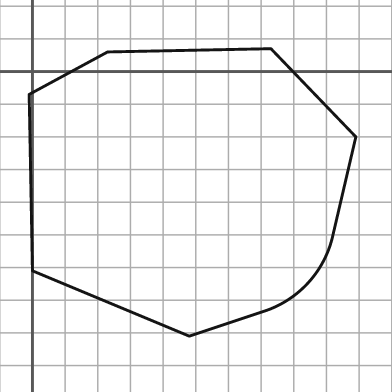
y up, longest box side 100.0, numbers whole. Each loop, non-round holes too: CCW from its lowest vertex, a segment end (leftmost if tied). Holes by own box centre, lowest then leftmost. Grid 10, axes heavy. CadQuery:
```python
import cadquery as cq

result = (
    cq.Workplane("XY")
    .moveTo(48.0, -81.0)
    .lineTo(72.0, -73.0)
    .threePointArc((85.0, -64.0), (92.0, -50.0))
    .lineTo(99.0, -20.0)
    .lineTo(73.0, 7.0)
    .lineTo(23.0, 6.0)
    .lineTo(-1.0, -7.0)
    .lineTo(0.0, -61.0)
    .close()
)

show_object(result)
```